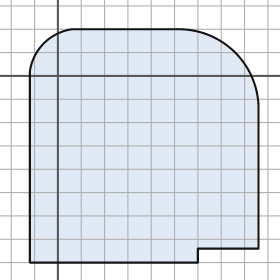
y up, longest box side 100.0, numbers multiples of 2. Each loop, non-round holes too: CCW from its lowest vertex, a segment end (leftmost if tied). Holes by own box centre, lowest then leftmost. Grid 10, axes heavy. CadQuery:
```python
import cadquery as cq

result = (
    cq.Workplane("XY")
    .moveTo(-12.0, -80.0)
    .lineTo(60.0, -80.0)
    .lineTo(60.0, -74.0)
    .lineTo(86.0, -74.0)
    .lineTo(86.0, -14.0)
    .threePointArc((76.0, 10.0), (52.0, 20.0))
    .lineTo(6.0, 20.0)
    .threePointArc((-6.0, 14.0), (-12.0, 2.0))
    .close()
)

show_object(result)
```